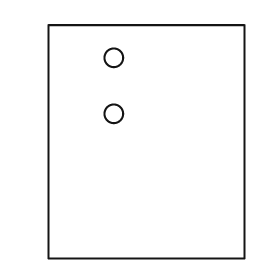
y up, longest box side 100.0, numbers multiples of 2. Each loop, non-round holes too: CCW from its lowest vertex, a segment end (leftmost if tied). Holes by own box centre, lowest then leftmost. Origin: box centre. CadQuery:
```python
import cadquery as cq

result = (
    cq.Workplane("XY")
    .moveTo(-42.0, -50.0)
    .lineTo(42.0, -50.0)
    .lineTo(42.0, 50.0)
    .lineTo(-42.0, 50.0)
    .close()
    .moveTo(-14.0, 12.0)
    .circle(4.0)
    .moveTo(-14.0, 36.0)
    .circle(4.0)
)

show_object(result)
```